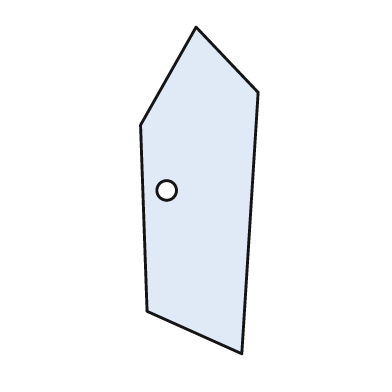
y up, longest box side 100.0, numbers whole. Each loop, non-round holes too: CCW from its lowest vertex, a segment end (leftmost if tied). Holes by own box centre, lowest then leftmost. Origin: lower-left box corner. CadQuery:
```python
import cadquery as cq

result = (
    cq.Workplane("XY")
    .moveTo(31.0, 0.0)
    .lineTo(36.0, 80.0)
    .lineTo(17.0, 100.0)
    .lineTo(0.0, 70.0)
    .lineTo(2.0, 13.0)
    .close()
    .moveTo(8.0, 50.0)
    .circle(3.0)
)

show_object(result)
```